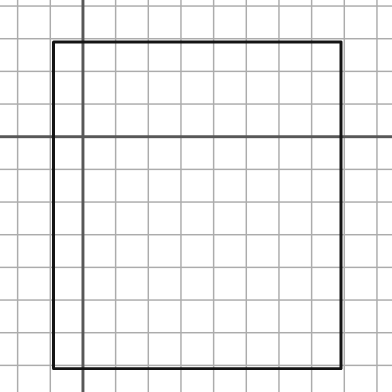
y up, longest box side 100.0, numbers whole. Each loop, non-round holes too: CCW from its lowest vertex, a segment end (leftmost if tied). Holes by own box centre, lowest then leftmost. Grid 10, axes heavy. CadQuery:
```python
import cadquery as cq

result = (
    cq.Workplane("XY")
    .moveTo(-9.0, -71.0)
    .lineTo(79.0, -71.0)
    .lineTo(79.0, 29.0)
    .lineTo(-9.0, 29.0)
    .close()
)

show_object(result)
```